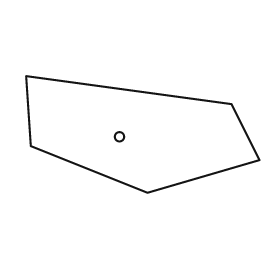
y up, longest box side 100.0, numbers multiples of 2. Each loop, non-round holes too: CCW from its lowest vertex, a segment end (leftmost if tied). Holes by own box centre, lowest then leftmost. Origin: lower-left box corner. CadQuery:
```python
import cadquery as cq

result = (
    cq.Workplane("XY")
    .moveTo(52.0, 0.0)
    .lineTo(100.0, 14.0)
    .lineTo(88.0, 38.0)
    .lineTo(0.0, 50.0)
    .lineTo(2.0, 20.0)
    .close()
    .moveTo(40.0, 24.0)
    .circle(2.0)
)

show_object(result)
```